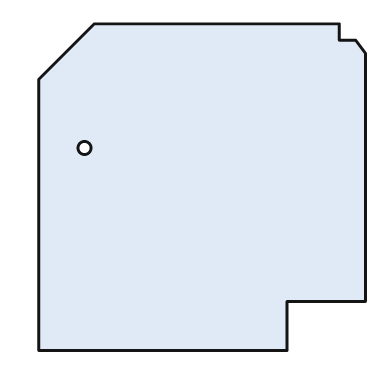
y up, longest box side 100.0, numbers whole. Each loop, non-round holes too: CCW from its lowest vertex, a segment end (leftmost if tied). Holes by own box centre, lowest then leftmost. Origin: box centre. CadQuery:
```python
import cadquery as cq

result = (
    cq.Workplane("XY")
    .moveTo(-50.0, -50.0)
    .lineTo(26.0, -50.0)
    .lineTo(26.0, -35.0)
    .lineTo(50.0, -35.0)
    .lineTo(50.0, 41.0)
    .lineTo(47.0, 45.0)
    .lineTo(42.0, 45.0)
    .lineTo(42.0, 50.0)
    .lineTo(-33.0, 50.0)
    .lineTo(-50.0, 33.0)
    .close()
    .moveTo(-36.0, 12.0)
    .circle(2.0)
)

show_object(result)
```